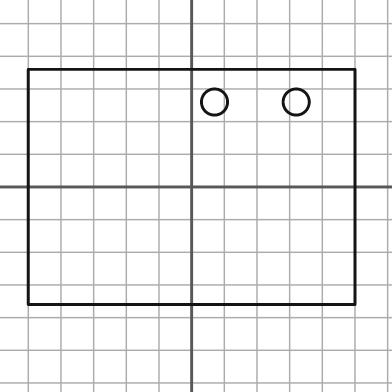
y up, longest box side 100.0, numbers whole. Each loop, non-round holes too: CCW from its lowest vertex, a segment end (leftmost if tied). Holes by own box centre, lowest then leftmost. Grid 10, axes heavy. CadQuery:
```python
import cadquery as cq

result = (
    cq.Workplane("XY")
    .moveTo(-50.0, -36.0)
    .lineTo(50.0, -36.0)
    .lineTo(50.0, 36.0)
    .lineTo(-50.0, 36.0)
    .close()
    .moveTo(7.0, 26.0)
    .circle(4.0)
    .moveTo(32.0, 26.0)
    .circle(4.0)
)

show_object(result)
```